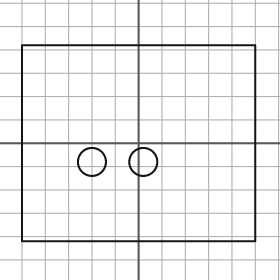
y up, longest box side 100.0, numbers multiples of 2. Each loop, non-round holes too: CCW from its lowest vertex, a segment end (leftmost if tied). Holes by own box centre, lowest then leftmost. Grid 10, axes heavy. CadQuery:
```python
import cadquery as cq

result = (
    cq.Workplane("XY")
    .moveTo(-50.0, -42.0)
    .lineTo(50.0, -42.0)
    .lineTo(50.0, 42.0)
    .lineTo(-50.0, 42.0)
    .close()
    .moveTo(-20.0, -8.0)
    .circle(6.0)
    .moveTo(2.0, -8.0)
    .circle(6.0)
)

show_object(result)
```